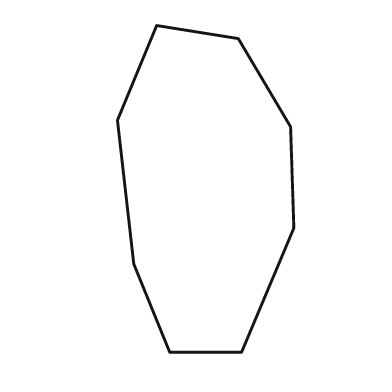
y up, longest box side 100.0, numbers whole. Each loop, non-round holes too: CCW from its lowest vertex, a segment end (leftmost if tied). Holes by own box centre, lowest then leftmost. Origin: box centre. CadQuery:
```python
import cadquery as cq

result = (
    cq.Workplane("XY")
    .moveTo(-11.0, -50.0)
    .lineTo(11.0, -50.0)
    .lineTo(27.0, -12.0)
    .lineTo(26.0, 19.0)
    .lineTo(10.0, 46.0)
    .lineTo(-15.0, 50.0)
    .lineTo(-27.0, 21.0)
    .lineTo(-22.0, -23.0)
    .close()
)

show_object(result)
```